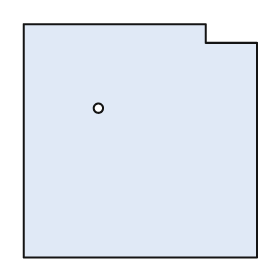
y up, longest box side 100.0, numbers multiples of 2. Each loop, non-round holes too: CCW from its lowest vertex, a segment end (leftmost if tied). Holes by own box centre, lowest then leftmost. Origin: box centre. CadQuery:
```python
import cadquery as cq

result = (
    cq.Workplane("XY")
    .moveTo(-50.0, -50.0)
    .lineTo(50.0, -50.0)
    .lineTo(50.0, 42.0)
    .lineTo(28.0, 42.0)
    .lineTo(28.0, 50.0)
    .lineTo(-50.0, 50.0)
    .close()
    .moveTo(-18.0, 14.0)
    .circle(2.0)
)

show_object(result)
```